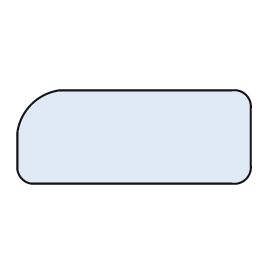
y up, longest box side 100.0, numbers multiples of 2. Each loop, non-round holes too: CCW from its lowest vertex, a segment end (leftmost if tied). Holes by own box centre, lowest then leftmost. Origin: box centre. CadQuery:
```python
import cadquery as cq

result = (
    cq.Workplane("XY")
    .moveTo(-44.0, -20.0)
    .lineTo(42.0, -20.0)
    .threePointArc((48.0, -18.0), (50.0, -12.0))
    .lineTo(50.0, 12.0)
    .threePointArc((48.0, 18.0), (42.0, 20.0))
    .lineTo(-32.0, 20.0)
    .threePointArc((-44.0, 14.0), (-50.0, 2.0))
    .lineTo(-50.0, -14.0)
    .threePointArc((-48.0, -18.0), (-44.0, -20.0))
    .close()
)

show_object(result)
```